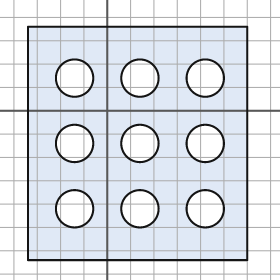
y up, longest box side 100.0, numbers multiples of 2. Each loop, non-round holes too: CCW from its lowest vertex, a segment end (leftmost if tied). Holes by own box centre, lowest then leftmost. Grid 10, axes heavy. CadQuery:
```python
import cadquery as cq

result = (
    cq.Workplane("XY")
    .moveTo(-34.0, -64.0)
    .lineTo(60.0, -64.0)
    .lineTo(60.0, 36.0)
    .lineTo(-34.0, 36.0)
    .close()
    .moveTo(-14.0, -42.0)
    .circle(8.0)
    .moveTo(14.0, -42.0)
    .circle(8.0)
    .moveTo(42.0, -42.0)
    .circle(8.0)
    .moveTo(-14.0, -14.0)
    .circle(8.0)
    .moveTo(14.0, -14.0)
    .circle(8.0)
    .moveTo(42.0, -14.0)
    .circle(8.0)
    .moveTo(-14.0, 14.0)
    .circle(8.0)
    .moveTo(14.0, 14.0)
    .circle(8.0)
    .moveTo(42.0, 14.0)
    .circle(8.0)
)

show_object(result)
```